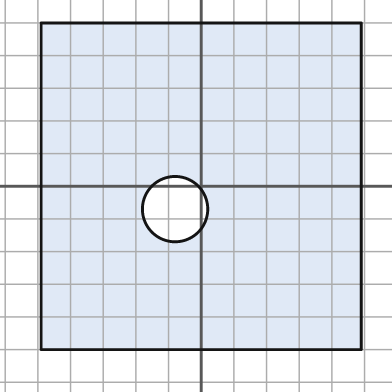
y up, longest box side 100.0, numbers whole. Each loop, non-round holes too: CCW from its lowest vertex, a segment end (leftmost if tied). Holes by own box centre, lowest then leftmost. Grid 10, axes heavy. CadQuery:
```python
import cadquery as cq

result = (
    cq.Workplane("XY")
    .moveTo(-49.0, -50.0)
    .lineTo(49.0, -50.0)
    .lineTo(49.0, 50.0)
    .lineTo(-49.0, 50.0)
    .close()
    .moveTo(-8.0, -7.0)
    .circle(10.0)
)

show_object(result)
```